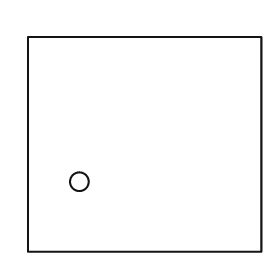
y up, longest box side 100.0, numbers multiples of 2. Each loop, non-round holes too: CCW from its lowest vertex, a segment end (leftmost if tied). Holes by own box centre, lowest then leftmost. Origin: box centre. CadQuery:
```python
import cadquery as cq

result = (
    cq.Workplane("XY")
    .moveTo(-50.0, -46.0)
    .lineTo(50.0, -46.0)
    .lineTo(50.0, 46.0)
    .lineTo(-50.0, 46.0)
    .close()
    .moveTo(-28.0, -16.0)
    .circle(4.0)
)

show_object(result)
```